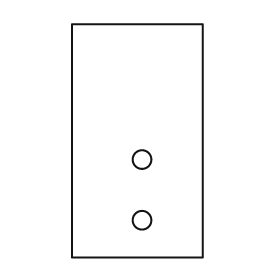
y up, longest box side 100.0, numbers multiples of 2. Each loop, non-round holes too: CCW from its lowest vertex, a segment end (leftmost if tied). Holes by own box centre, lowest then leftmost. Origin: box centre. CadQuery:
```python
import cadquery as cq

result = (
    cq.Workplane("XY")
    .moveTo(-28.0, -50.0)
    .lineTo(28.0, -50.0)
    .lineTo(28.0, 50.0)
    .lineTo(-28.0, 50.0)
    .close()
    .moveTo(2.0, -34.0)
    .circle(4.0)
    .moveTo(2.0, -8.0)
    .circle(4.0)
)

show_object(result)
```